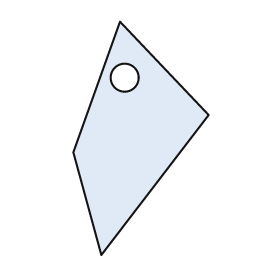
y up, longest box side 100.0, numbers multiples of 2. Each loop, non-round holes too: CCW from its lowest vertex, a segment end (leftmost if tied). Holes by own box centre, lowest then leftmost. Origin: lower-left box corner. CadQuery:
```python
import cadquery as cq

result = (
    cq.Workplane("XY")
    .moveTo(12.0, 0.0)
    .lineTo(58.0, 60.0)
    .lineTo(20.0, 100.0)
    .lineTo(0.0, 44.0)
    .close()
    .moveTo(22.0, 76.0)
    .circle(6.0)
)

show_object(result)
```